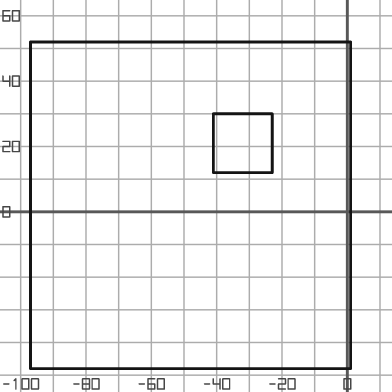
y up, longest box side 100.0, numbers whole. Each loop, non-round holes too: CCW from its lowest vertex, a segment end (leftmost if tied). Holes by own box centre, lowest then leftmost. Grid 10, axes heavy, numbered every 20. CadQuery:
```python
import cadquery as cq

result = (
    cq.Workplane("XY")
    .moveTo(-97.0, -48.0)
    .lineTo(1.0, -48.0)
    .lineTo(1.0, 52.0)
    .lineTo(-97.0, 52.0)
    .close()
    .moveTo(-41.0, 12.0)
    .lineTo(-23.0, 12.0)
    .lineTo(-23.0, 30.0)
    .lineTo(-41.0, 30.0)
    .close()
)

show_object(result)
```